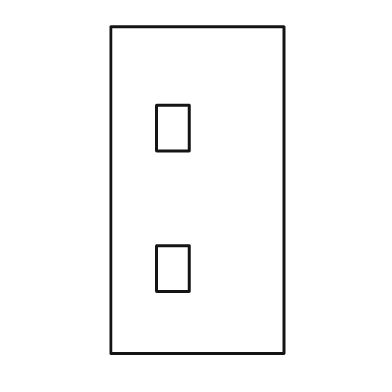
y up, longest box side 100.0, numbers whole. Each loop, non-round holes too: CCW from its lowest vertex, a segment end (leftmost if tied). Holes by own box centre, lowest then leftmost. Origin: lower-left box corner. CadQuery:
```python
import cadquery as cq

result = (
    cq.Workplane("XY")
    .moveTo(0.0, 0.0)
    .lineTo(53.0, 0.0)
    .lineTo(53.0, 100.0)
    .lineTo(0.0, 100.0)
    .close()
    .moveTo(14.0, 19.0)
    .lineTo(24.0, 19.0)
    .lineTo(24.0, 33.0)
    .lineTo(14.0, 33.0)
    .close()
    .moveTo(14.0, 62.0)
    .lineTo(24.0, 62.0)
    .lineTo(24.0, 76.0)
    .lineTo(14.0, 76.0)
    .close()
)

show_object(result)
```